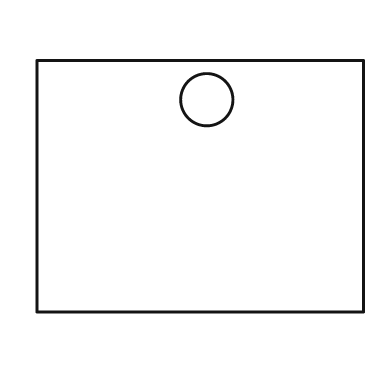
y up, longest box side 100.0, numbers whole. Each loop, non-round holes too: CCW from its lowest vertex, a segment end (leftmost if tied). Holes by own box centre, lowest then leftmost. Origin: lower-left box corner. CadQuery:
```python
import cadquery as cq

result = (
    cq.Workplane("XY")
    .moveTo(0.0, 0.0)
    .lineTo(100.0, 0.0)
    .lineTo(100.0, 77.0)
    .lineTo(0.0, 77.0)
    .close()
    .moveTo(52.0, 65.0)
    .circle(8.0)
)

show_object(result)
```